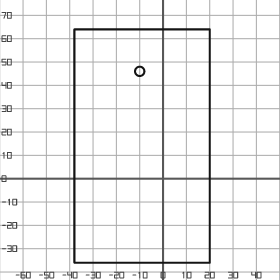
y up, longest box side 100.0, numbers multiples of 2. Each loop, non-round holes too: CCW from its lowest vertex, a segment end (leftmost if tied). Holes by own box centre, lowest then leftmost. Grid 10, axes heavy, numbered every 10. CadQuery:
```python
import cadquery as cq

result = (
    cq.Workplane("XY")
    .moveTo(-38.0, -36.0)
    .lineTo(20.0, -36.0)
    .lineTo(20.0, 64.0)
    .lineTo(-38.0, 64.0)
    .close()
    .moveTo(-10.0, 46.0)
    .circle(2.0)
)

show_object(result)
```